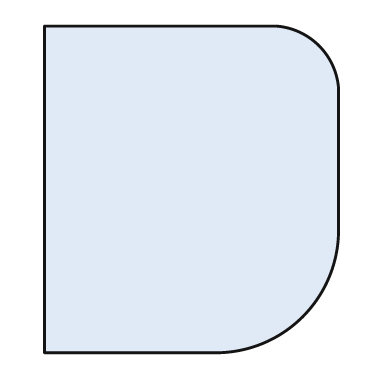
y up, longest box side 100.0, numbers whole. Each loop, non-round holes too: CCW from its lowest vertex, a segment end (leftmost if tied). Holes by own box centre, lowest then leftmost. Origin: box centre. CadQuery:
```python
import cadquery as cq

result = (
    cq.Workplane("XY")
    .moveTo(-45.0, -50.0)
    .lineTo(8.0, -50.0)
    .threePointArc((34.0, -39.0), (45.0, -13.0))
    .lineTo(45.0, 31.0)
    .threePointArc((39.0, 44.0), (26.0, 50.0))
    .lineTo(-45.0, 50.0)
    .close()
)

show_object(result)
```